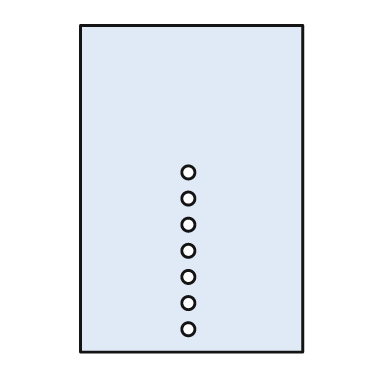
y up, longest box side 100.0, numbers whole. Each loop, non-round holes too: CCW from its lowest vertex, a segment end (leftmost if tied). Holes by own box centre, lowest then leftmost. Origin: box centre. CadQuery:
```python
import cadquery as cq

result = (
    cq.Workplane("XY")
    .moveTo(-34.0, -50.0)
    .lineTo(34.0, -50.0)
    .lineTo(34.0, 50.0)
    .lineTo(-34.0, 50.0)
    .close()
    .moveTo(-1.0, -43.0)
    .circle(2.0)
    .moveTo(-1.0, -35.0)
    .circle(2.0)
    .moveTo(-1.0, -27.0)
    .circle(2.0)
    .moveTo(-1.0, -19.0)
    .circle(2.0)
    .moveTo(-1.0, -11.0)
    .circle(2.0)
    .moveTo(-1.0, -3.0)
    .circle(2.0)
    .moveTo(-1.0, 5.0)
    .circle(2.0)
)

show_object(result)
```